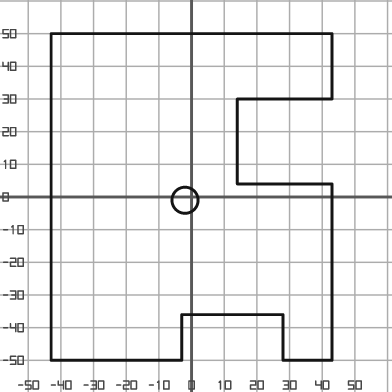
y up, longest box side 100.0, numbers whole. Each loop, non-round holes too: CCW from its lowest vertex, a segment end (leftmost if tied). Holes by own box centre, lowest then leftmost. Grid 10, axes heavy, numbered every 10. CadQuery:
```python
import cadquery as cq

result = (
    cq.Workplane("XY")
    .moveTo(-43.0, -50.0)
    .lineTo(-3.0, -50.0)
    .lineTo(-3.0, -36.0)
    .lineTo(28.0, -36.0)
    .lineTo(28.0, -50.0)
    .lineTo(43.0, -50.0)
    .lineTo(43.0, 4.0)
    .lineTo(14.0, 4.0)
    .lineTo(14.0, 30.0)
    .lineTo(43.0, 30.0)
    .lineTo(43.0, 50.0)
    .lineTo(-43.0, 50.0)
    .close()
    .moveTo(-2.0, -1.0)
    .circle(4.0)
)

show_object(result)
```